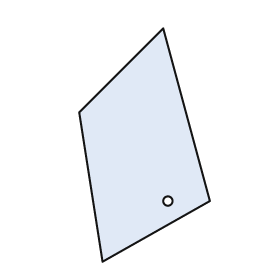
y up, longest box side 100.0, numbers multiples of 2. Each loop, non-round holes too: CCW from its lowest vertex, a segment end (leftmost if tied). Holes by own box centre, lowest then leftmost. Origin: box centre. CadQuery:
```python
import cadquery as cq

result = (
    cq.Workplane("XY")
    .moveTo(-18.0, -50.0)
    .lineTo(28.0, -24.0)
    .lineTo(8.0, 50.0)
    .lineTo(-28.0, 14.0)
    .close()
    .moveTo(10.0, -24.0)
    .circle(2.0)
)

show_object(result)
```